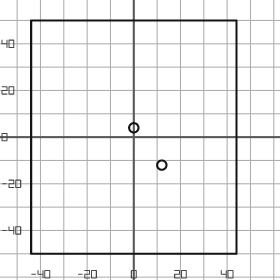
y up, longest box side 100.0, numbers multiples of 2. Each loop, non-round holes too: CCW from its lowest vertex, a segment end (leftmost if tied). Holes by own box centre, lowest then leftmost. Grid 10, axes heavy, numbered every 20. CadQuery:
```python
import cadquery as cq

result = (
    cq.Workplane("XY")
    .moveTo(-44.0, -50.0)
    .lineTo(44.0, -50.0)
    .lineTo(44.0, 50.0)
    .lineTo(-44.0, 50.0)
    .close()
    .moveTo(12.0, -12.0)
    .circle(2.0)
    .moveTo(0.0, 4.0)
    .circle(2.0)
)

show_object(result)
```